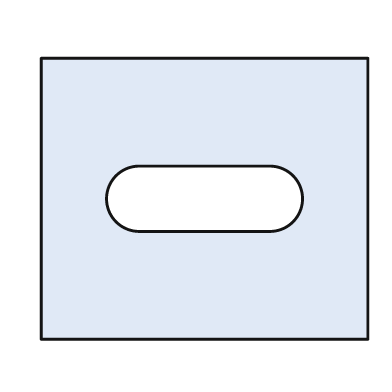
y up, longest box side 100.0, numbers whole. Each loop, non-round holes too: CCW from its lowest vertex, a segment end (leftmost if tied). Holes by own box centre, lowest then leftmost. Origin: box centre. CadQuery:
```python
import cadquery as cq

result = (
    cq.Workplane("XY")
    .moveTo(-50.0, -43.0)
    .lineTo(50.0, -43.0)
    .lineTo(50.0, 43.0)
    .lineTo(-50.0, 43.0)
    .close()
    .moveTo(-20.0, -10.0)
    .lineTo(20.0, -10.0)
    .threePointArc((30.0, 0.0), (20.0, 10.0))
    .lineTo(-20.0, 10.0)
    .threePointArc((-30.0, 0.0), (-20.0, -10.0))
    .close()
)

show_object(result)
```